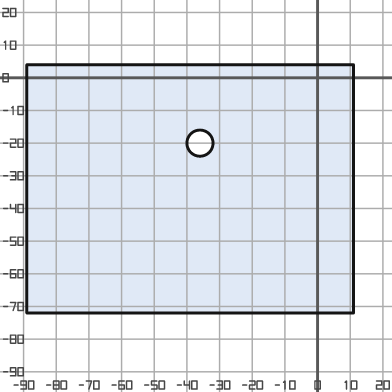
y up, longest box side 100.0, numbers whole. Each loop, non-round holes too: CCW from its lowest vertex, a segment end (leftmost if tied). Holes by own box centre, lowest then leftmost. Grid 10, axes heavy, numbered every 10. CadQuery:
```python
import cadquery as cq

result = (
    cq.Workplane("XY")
    .moveTo(-89.0, -72.0)
    .lineTo(11.0, -72.0)
    .lineTo(11.0, 4.0)
    .lineTo(-89.0, 4.0)
    .close()
    .moveTo(-36.0, -20.0)
    .circle(4.0)
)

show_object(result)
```